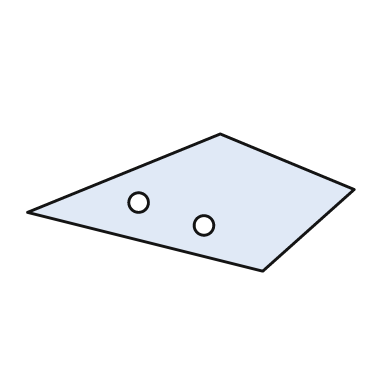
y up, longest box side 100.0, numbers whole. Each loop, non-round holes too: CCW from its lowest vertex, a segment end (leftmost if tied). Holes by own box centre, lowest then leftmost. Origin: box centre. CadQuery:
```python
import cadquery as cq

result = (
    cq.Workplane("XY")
    .moveTo(22.0, -21.0)
    .lineTo(50.0, 4.0)
    .lineTo(9.0, 21.0)
    .lineTo(-50.0, -3.0)
    .close()
    .moveTo(4.0, -7.0)
    .circle(3.0)
    .moveTo(-16.0, 0.0)
    .circle(3.0)
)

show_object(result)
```